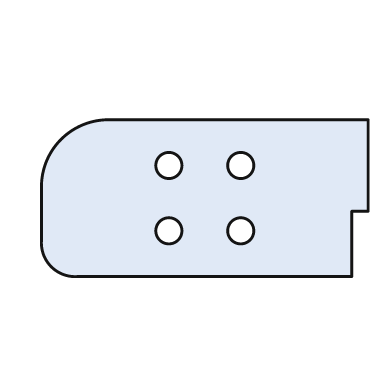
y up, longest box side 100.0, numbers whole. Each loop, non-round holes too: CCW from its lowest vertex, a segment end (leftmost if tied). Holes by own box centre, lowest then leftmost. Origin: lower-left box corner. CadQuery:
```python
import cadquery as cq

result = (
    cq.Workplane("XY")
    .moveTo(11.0, 0.0)
    .lineTo(95.0, 0.0)
    .lineTo(95.0, 20.0)
    .lineTo(100.0, 20.0)
    .lineTo(100.0, 48.0)
    .lineTo(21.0, 48.0)
    .threePointArc((6.0, 42.0), (0.0, 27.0))
    .lineTo(0.0, 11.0)
    .threePointArc((3.0, 3.0), (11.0, 0.0))
    .close()
    .moveTo(39.0, 14.0)
    .circle(4.0)
    .moveTo(61.0, 14.0)
    .circle(4.0)
    .moveTo(39.0, 34.0)
    .circle(4.0)
    .moveTo(61.0, 34.0)
    .circle(4.0)
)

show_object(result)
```